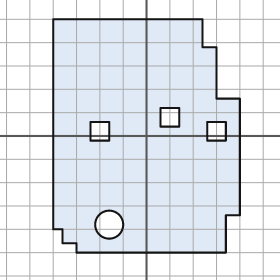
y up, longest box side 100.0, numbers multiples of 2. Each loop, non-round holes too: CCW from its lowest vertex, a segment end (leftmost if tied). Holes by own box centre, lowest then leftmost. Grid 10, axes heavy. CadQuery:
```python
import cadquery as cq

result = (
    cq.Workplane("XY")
    .moveTo(-30.0, -50.0)
    .lineTo(34.0, -50.0)
    .lineTo(34.0, -34.0)
    .lineTo(40.0, -34.0)
    .lineTo(40.0, 16.0)
    .lineTo(30.0, 16.0)
    .lineTo(30.0, 38.0)
    .lineTo(24.0, 38.0)
    .lineTo(24.0, 50.0)
    .lineTo(-40.0, 50.0)
    .lineTo(-40.0, -40.0)
    .lineTo(-36.0, -40.0)
    .lineTo(-36.0, -46.0)
    .lineTo(-30.0, -46.0)
    .close()
    .moveTo(-16.0, -38.0)
    .circle(6.0)
    .moveTo(-24.0, -2.0)
    .lineTo(-16.0, -2.0)
    .lineTo(-16.0, 6.0)
    .lineTo(-24.0, 6.0)
    .close()
    .moveTo(26.0, -2.0)
    .lineTo(34.0, -2.0)
    .lineTo(34.0, 6.0)
    .lineTo(26.0, 6.0)
    .close()
    .moveTo(6.0, 4.0)
    .lineTo(14.0, 4.0)
    .lineTo(14.0, 12.0)
    .lineTo(6.0, 12.0)
    .close()
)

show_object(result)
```